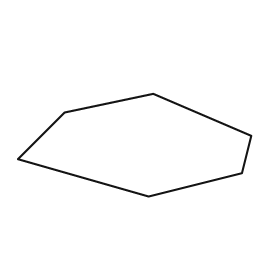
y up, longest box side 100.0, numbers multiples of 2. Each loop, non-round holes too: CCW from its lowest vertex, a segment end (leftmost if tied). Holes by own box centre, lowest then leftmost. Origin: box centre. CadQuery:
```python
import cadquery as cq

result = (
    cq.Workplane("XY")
    .moveTo(6.0, -22.0)
    .lineTo(46.0, -12.0)
    .lineTo(50.0, 4.0)
    .lineTo(8.0, 22.0)
    .lineTo(-30.0, 14.0)
    .lineTo(-50.0, -6.0)
    .close()
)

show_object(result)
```